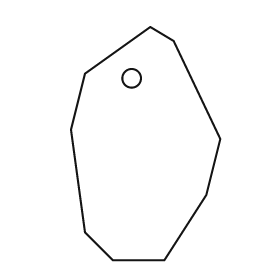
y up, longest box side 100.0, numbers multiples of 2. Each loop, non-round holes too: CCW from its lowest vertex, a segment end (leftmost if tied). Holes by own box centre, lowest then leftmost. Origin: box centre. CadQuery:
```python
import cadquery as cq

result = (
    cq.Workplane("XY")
    .moveTo(-14.0, -50.0)
    .lineTo(8.0, -50.0)
    .lineTo(26.0, -22.0)
    .lineTo(32.0, 2.0)
    .lineTo(12.0, 44.0)
    .lineTo(2.0, 50.0)
    .lineTo(-26.0, 30.0)
    .lineTo(-32.0, 6.0)
    .lineTo(-26.0, -38.0)
    .close()
    .moveTo(-6.0, 28.0)
    .circle(4.0)
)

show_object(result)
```